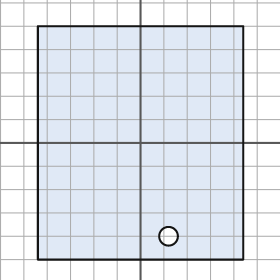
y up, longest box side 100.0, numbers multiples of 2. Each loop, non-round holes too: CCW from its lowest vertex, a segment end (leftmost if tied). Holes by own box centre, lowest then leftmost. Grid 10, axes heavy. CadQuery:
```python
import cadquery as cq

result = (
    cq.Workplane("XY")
    .moveTo(-44.0, -50.0)
    .lineTo(44.0, -50.0)
    .lineTo(44.0, 50.0)
    .lineTo(-44.0, 50.0)
    .close()
    .moveTo(12.0, -40.0)
    .circle(4.0)
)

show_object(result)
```